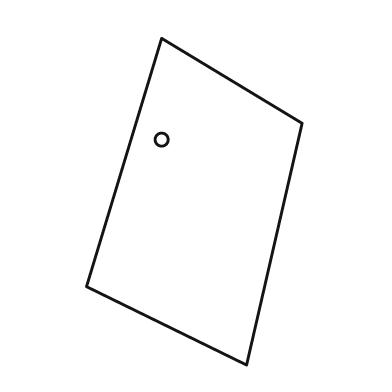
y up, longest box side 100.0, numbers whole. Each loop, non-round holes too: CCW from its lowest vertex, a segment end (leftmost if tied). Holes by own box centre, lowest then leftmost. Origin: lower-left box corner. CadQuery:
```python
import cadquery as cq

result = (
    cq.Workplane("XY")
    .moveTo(49.0, 0.0)
    .lineTo(66.0, 74.0)
    .lineTo(23.0, 100.0)
    .lineTo(0.0, 24.0)
    .close()
    .moveTo(23.0, 69.0)
    .circle(2.0)
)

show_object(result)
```